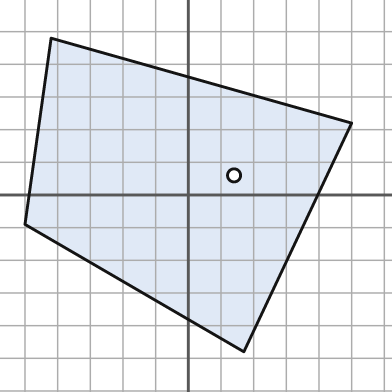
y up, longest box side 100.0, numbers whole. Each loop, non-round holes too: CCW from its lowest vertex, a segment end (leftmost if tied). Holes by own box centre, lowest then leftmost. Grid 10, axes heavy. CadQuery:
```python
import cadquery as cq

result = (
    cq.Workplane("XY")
    .moveTo(17.0, -48.0)
    .lineTo(50.0, 22.0)
    .lineTo(-42.0, 48.0)
    .lineTo(-50.0, -9.0)
    .close()
    .moveTo(14.0, 6.0)
    .circle(2.0)
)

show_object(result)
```